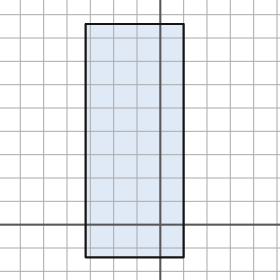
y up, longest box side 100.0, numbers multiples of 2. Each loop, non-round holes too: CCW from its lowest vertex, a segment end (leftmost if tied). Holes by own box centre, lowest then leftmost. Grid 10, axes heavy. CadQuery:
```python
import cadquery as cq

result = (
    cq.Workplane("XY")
    .moveTo(-32.0, -14.0)
    .lineTo(10.0, -14.0)
    .lineTo(10.0, 86.0)
    .lineTo(-32.0, 86.0)
    .close()
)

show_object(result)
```